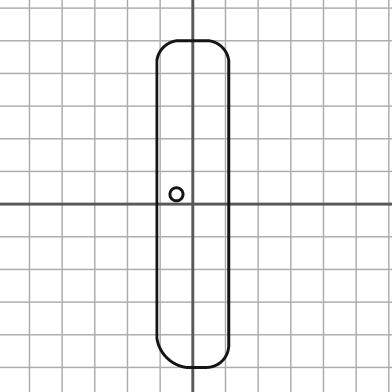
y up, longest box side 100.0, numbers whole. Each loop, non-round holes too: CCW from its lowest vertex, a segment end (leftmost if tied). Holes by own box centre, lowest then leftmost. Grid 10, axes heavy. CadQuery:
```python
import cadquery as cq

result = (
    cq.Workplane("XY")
    .moveTo(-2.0, -50.0)
    .lineTo(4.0, -50.0)
    .threePointArc((9.0, -48.0), (11.0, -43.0))
    .lineTo(11.0, 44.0)
    .threePointArc((9.0, 48.0), (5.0, 50.0))
    .lineTo(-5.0, 50.0)
    .threePointArc((-9.0, 48.0), (-11.0, 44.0))
    .lineTo(-11.0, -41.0)
    .threePointArc((-8.0, -47.0), (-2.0, -50.0))
    .close()
    .moveTo(-5.0, 3.0)
    .circle(2.0)
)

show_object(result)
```